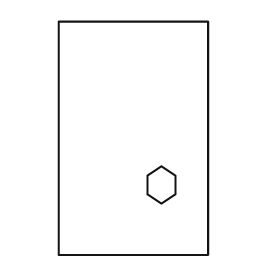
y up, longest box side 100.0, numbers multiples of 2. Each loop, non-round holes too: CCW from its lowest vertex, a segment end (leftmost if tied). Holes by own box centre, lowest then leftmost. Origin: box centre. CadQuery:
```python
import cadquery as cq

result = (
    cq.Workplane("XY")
    .moveTo(-32.0, -50.0)
    .lineTo(32.0, -50.0)
    .lineTo(32.0, 50.0)
    .lineTo(-32.0, 50.0)
    .close()
    .moveTo(12.0, -28.0)
    .lineTo(18.0, -24.0)
    .lineTo(18.0, -16.0)
    .lineTo(12.0, -12.0)
    .lineTo(6.0, -16.0)
    .lineTo(6.0, -24.0)
    .close()
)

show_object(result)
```